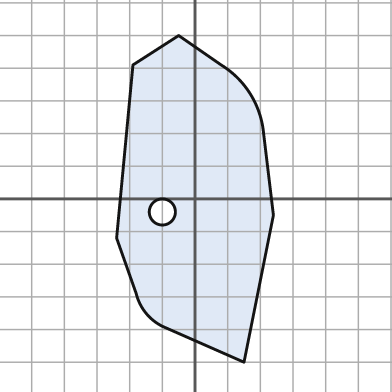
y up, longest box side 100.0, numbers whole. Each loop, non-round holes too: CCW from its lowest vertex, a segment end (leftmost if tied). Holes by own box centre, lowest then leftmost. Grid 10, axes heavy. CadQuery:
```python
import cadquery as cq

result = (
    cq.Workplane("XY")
    .moveTo(15.0, -50.0)
    .lineTo(24.0, -5.0)
    .lineTo(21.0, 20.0)
    .threePointArc((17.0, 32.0), (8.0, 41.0))
    .lineTo(-5.0, 50.0)
    .lineTo(-19.0, 41.0)
    .lineTo(-24.0, -12.0)
    .lineTo(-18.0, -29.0)
    .threePointArc((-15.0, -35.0), (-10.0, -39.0))
    .close()
    .moveTo(-10.0, -4.0)
    .circle(4.0)
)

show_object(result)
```